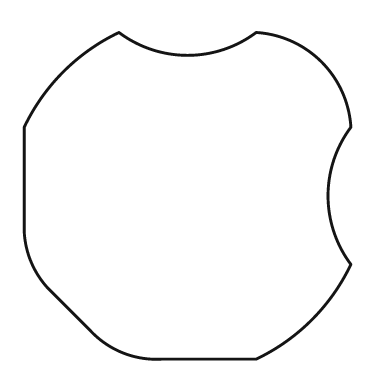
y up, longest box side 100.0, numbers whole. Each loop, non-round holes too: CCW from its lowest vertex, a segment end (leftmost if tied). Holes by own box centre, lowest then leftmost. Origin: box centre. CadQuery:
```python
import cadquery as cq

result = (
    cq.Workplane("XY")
    .moveTo(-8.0, -50.0)
    .lineTo(21.0, -50.0)
    .threePointArc((38.0, -38.0), (50.0, -21.0))
    .threePointArc((43.0, 0.0), (50.0, 21.0))
    .threePointArc((41.0, 41.0), (21.0, 50.0))
    .threePointArc((0.0, 43.0), (-21.0, 50.0))
    .threePointArc((-38.0, 38.0), (-50.0, 21.0))
    .lineTo(-50.0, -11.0)
    .threePointArc((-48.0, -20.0), (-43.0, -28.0))
    .lineTo(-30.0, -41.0)
    .threePointArc((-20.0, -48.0), (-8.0, -50.0))
    .close()
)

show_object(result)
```